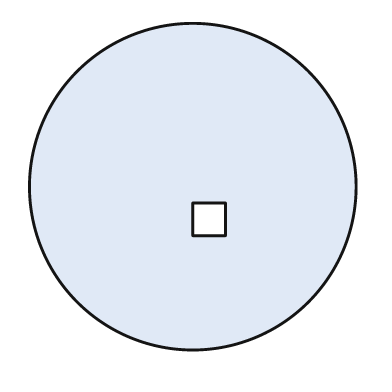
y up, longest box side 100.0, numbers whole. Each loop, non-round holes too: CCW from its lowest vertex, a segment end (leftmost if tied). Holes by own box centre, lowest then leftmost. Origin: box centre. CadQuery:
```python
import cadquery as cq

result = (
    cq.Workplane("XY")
    .moveTo(0.0, 0.0)
    .circle(50.0)
    .moveTo(0.0, -15.0)
    .lineTo(10.0, -15.0)
    .lineTo(10.0, -5.0)
    .lineTo(0.0, -5.0)
    .close()
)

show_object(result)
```